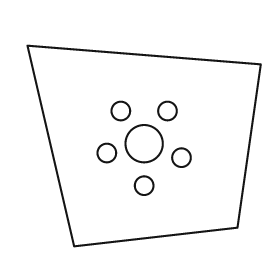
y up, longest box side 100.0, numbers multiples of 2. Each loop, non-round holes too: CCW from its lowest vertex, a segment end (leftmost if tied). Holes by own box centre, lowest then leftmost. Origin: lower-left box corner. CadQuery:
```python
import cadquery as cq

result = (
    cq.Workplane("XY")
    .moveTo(20.0, 0.0)
    .lineTo(90.0, 8.0)
    .lineTo(100.0, 78.0)
    .lineTo(0.0, 86.0)
    .close()
    .moveTo(50.0, 26.0)
    .circle(4.0)
    .moveTo(66.0, 38.0)
    .circle(4.0)
    .moveTo(34.0, 40.0)
    .circle(4.0)
    .moveTo(50.0, 44.0)
    .circle(8.0)
    .moveTo(40.0, 58.0)
    .circle(4.0)
    .moveTo(60.0, 58.0)
    .circle(4.0)
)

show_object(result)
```